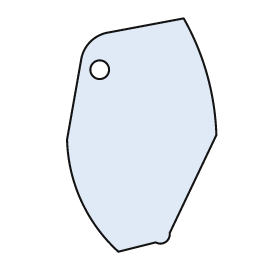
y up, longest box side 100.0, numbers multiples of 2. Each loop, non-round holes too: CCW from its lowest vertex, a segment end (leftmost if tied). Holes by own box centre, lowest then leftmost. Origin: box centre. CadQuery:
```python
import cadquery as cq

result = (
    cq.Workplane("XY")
    .moveTo(-10.0, -50.0)
    .lineTo(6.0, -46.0)
    .threePointArc((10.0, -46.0), (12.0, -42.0))
    .lineTo(32.0, 0.0)
    .threePointArc((28.0, 26.0), (18.0, 50.0))
    .lineTo(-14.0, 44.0)
    .threePointArc((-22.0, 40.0), (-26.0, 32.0))
    .lineTo(-32.0, -2.0)
    .threePointArc((-26.0, -28.0), (-10.0, -50.0))
    .close()
    .moveTo(-18.0, 28.0)
    .circle(4.0)
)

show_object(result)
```